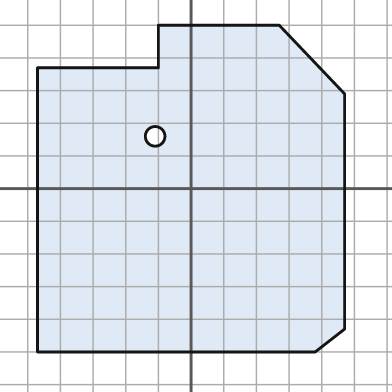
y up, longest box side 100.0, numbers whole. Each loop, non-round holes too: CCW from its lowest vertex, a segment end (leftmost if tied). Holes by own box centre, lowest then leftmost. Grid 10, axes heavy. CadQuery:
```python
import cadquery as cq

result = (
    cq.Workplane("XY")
    .moveTo(-47.0, -50.0)
    .lineTo(38.0, -50.0)
    .lineTo(47.0, -43.0)
    .lineTo(47.0, 29.0)
    .lineTo(27.0, 50.0)
    .lineTo(-10.0, 50.0)
    .lineTo(-10.0, 37.0)
    .lineTo(-47.0, 37.0)
    .close()
    .moveTo(-11.0, 16.0)
    .circle(3.0)
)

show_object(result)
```